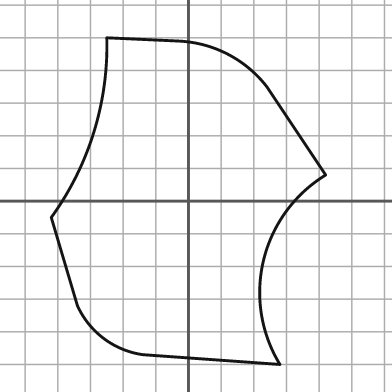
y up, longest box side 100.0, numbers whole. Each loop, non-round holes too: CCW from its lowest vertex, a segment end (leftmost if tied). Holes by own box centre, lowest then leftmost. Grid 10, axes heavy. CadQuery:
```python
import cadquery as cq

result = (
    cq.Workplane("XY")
    .moveTo(28.0, -50.0)
    .threePointArc((23.0, -18.0), (42.0, 8.0))
    .lineTo(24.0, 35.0)
    .threePointArc((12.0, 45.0), (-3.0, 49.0))
    .lineTo(-25.0, 50.0)
    .threePointArc((-29.0, 21.0), (-42.0, -5.0))
    .lineTo(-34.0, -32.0)
    .threePointArc((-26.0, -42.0), (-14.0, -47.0))
    .close()
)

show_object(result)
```